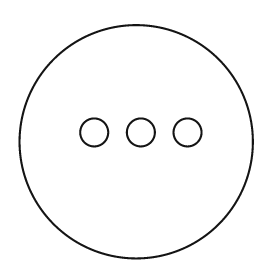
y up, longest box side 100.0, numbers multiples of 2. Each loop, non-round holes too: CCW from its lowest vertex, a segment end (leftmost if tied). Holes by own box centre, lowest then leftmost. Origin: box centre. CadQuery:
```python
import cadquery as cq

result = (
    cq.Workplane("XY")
    .moveTo(0.0, 0.0)
    .circle(50.0)
    .moveTo(-18.0, 4.0)
    .circle(6.0)
    .moveTo(2.0, 4.0)
    .circle(6.0)
    .moveTo(22.0, 4.0)
    .circle(6.0)
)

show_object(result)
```